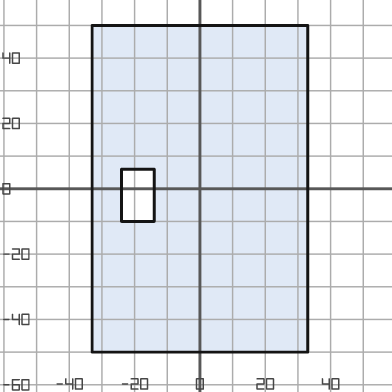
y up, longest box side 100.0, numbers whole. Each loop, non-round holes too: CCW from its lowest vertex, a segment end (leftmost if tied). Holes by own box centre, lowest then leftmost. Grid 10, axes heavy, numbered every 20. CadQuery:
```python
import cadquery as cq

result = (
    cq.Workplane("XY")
    .moveTo(-33.0, -50.0)
    .lineTo(33.0, -50.0)
    .lineTo(33.0, 50.0)
    .lineTo(-33.0, 50.0)
    .close()
    .moveTo(-24.0, -10.0)
    .lineTo(-14.0, -10.0)
    .lineTo(-14.0, 6.0)
    .lineTo(-24.0, 6.0)
    .close()
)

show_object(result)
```